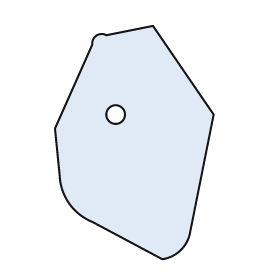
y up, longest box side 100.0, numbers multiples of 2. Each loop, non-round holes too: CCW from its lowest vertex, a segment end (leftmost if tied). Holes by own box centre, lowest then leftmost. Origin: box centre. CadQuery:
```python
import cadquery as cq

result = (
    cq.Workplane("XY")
    .moveTo(12.0, -50.0)
    .threePointArc((20.0, -46.0), (24.0, -38.0))
    .lineTo(34.0, 12.0)
    .lineTo(8.0, 50.0)
    .lineTo(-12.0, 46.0)
    .threePointArc((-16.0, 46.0), (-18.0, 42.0))
    .lineTo(-34.0, 6.0)
    .lineTo(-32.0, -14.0)
    .threePointArc((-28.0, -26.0), (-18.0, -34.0))
    .close()
    .moveTo(-8.0, 12.0)
    .circle(4.0)
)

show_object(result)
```